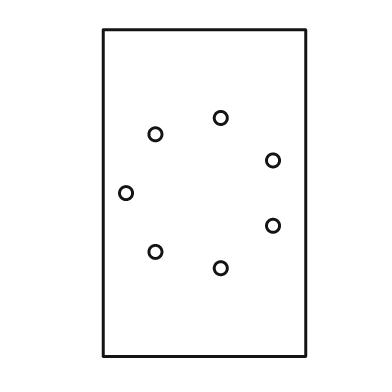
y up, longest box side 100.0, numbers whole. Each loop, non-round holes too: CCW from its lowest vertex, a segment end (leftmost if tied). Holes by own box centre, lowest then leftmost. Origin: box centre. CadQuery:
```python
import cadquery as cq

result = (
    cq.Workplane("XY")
    .moveTo(-31.0, -50.0)
    .lineTo(31.0, -50.0)
    .lineTo(31.0, 50.0)
    .lineTo(-31.0, 50.0)
    .close()
    .moveTo(5.0, -23.0)
    .circle(2.0)
    .moveTo(-15.0, -18.0)
    .circle(2.0)
    .moveTo(21.0, -10.0)
    .circle(2.0)
    .moveTo(-24.0, 0.0)
    .circle(2.0)
    .moveTo(21.0, 10.0)
    .circle(2.0)
    .moveTo(-15.0, 18.0)
    .circle(2.0)
    .moveTo(5.0, 23.0)
    .circle(2.0)
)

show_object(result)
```